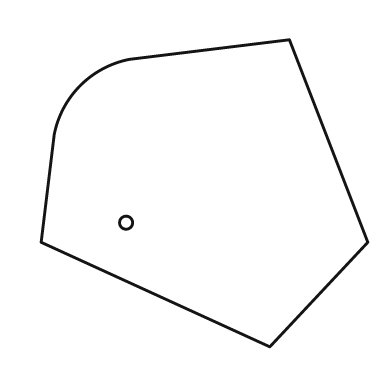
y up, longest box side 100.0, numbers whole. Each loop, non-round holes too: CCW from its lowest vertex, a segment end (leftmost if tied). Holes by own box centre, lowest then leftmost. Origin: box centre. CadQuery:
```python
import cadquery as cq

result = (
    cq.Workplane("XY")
    .moveTo(20.0, -47.0)
    .lineTo(50.0, -15.0)
    .lineTo(26.0, 47.0)
    .lineTo(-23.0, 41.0)
    .threePointArc((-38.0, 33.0), (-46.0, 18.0))
    .lineTo(-50.0, -15.0)
    .close()
    .moveTo(-24.0, -9.0)
    .circle(2.0)
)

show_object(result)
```